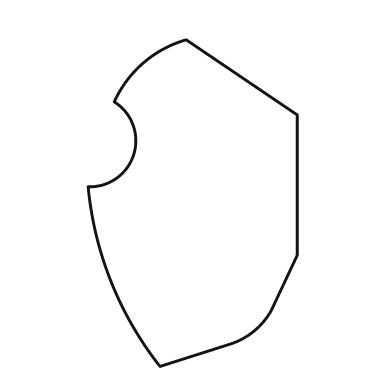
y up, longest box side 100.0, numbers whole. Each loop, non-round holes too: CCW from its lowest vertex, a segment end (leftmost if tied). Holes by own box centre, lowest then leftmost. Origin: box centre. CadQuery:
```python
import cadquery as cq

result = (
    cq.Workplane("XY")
    .moveTo(-10.0, -50.0)
    .lineTo(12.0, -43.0)
    .threePointArc((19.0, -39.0), (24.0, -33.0))
    .lineTo(32.0, -16.0)
    .lineTo(32.0, 27.0)
    .lineTo(-2.0, 50.0)
    .threePointArc((-15.0, 43.0), (-24.0, 31.0))
    .threePointArc((-18.0, 15.0), (-32.0, 5.0))
    .threePointArc((-25.0, -24.0), (-10.0, -50.0))
    .close()
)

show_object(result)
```